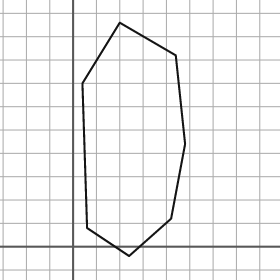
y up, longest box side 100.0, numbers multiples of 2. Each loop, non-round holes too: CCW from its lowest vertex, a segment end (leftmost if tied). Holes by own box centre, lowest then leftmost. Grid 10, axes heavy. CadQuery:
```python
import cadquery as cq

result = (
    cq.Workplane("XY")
    .moveTo(24.0, -4.0)
    .lineTo(42.0, 12.0)
    .lineTo(48.0, 44.0)
    .lineTo(44.0, 82.0)
    .lineTo(20.0, 96.0)
    .lineTo(4.0, 70.0)
    .lineTo(6.0, 8.0)
    .close()
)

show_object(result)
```